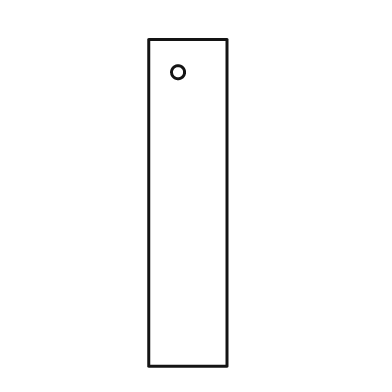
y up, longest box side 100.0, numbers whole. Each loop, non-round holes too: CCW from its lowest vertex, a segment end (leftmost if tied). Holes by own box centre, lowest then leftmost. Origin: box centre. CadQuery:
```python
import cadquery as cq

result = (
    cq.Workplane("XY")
    .moveTo(-12.0, -50.0)
    .lineTo(12.0, -50.0)
    .lineTo(12.0, 50.0)
    .lineTo(-12.0, 50.0)
    .close()
    .moveTo(-3.0, 40.0)
    .circle(2.0)
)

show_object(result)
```